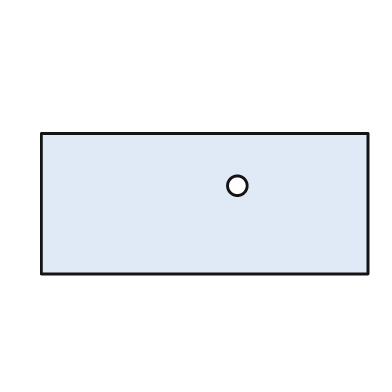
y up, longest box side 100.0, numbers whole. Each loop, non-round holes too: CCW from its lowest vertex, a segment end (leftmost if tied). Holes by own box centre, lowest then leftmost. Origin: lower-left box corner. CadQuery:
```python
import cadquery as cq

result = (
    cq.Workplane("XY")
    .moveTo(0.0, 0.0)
    .lineTo(100.0, 0.0)
    .lineTo(100.0, 43.0)
    .lineTo(0.0, 43.0)
    .close()
    .moveTo(60.0, 27.0)
    .circle(3.0)
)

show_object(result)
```